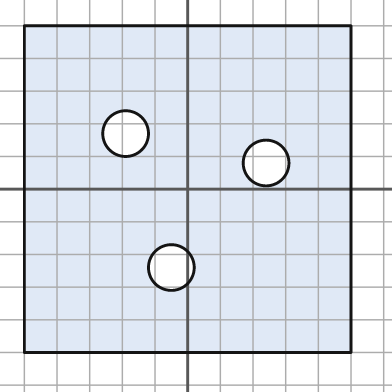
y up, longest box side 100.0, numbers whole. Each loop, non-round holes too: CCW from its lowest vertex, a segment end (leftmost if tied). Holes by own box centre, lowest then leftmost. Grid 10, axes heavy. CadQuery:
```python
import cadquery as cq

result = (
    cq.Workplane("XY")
    .moveTo(-50.0, -50.0)
    .lineTo(50.0, -50.0)
    .lineTo(50.0, 50.0)
    .lineTo(-50.0, 50.0)
    .close()
    .moveTo(-5.0, -24.0)
    .circle(7.0)
    .moveTo(24.0, 8.0)
    .circle(7.0)
    .moveTo(-19.0, 17.0)
    .circle(7.0)
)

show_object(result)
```